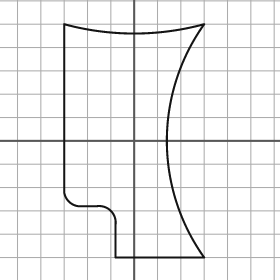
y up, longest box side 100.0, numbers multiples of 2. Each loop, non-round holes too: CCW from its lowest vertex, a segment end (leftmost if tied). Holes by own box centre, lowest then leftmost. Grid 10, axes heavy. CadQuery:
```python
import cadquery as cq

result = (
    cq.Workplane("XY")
    .moveTo(-8.0, -50.0)
    .lineTo(30.0, -50.0)
    .threePointArc((14.0, 0.0), (30.0, 50.0))
    .threePointArc((0.0, 46.0), (-30.0, 50.0))
    .lineTo(-30.0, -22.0)
    .threePointArc((-28.0, -26.0), (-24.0, -28.0))
    .lineTo(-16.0, -28.0)
    .threePointArc((-10.0, -30.0), (-8.0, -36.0))
    .close()
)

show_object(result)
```